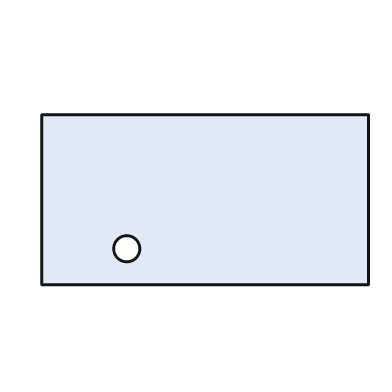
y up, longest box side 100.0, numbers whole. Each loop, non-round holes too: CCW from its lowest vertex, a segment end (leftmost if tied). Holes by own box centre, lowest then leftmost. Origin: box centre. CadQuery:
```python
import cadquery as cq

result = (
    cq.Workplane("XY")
    .moveTo(-50.0, -26.0)
    .lineTo(50.0, -26.0)
    .lineTo(50.0, 26.0)
    .lineTo(-50.0, 26.0)
    .close()
    .moveTo(-24.0, -15.0)
    .circle(4.0)
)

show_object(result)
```